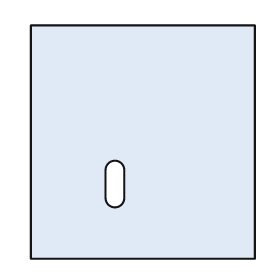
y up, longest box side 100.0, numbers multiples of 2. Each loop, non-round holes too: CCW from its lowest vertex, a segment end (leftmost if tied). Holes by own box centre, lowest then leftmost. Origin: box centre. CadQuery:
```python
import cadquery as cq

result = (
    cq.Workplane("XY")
    .moveTo(-48.0, -50.0)
    .lineTo(48.0, -50.0)
    .lineTo(48.0, 50.0)
    .lineTo(-48.0, 50.0)
    .close()
    .moveTo(-16.0, -24.0)
    .threePointArc((-12.0, -28.0), (-8.0, -24.0))
    .lineTo(-8.0, -12.0)
    .threePointArc((-12.0, -8.0), (-16.0, -12.0))
    .close()
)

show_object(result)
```